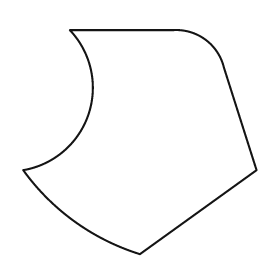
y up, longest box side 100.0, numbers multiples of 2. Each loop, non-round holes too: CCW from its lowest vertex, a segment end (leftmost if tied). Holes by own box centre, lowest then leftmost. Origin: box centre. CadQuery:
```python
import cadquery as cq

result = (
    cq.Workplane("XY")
    .moveTo(0.0, -48.0)
    .lineTo(50.0, -12.0)
    .lineTo(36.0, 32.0)
    .threePointArc((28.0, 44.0), (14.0, 48.0))
    .lineTo(-30.0, 48.0)
    .threePointArc((-22.0, 12.0), (-50.0, -12.0))
    .threePointArc((-28.0, -34.0), (0.0, -48.0))
    .close()
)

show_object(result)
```